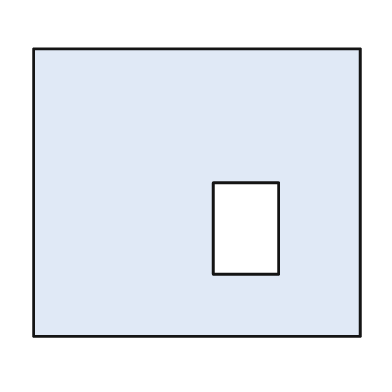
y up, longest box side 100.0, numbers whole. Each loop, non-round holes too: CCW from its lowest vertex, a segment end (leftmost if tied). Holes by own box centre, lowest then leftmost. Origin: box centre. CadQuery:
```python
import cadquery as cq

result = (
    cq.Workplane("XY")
    .moveTo(-50.0, -44.0)
    .lineTo(50.0, -44.0)
    .lineTo(50.0, 44.0)
    .lineTo(-50.0, 44.0)
    .close()
    .moveTo(5.0, -25.0)
    .lineTo(25.0, -25.0)
    .lineTo(25.0, 3.0)
    .lineTo(5.0, 3.0)
    .close()
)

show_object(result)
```